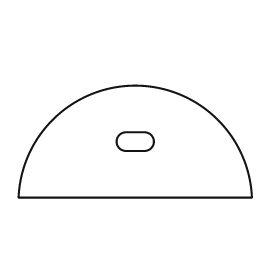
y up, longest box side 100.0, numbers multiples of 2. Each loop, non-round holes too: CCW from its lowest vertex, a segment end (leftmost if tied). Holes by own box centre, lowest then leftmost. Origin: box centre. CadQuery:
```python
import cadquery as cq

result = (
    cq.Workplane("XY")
    .moveTo(-50.0, -24.0)
    .lineTo(50.0, -24.0)
    .threePointArc((0.0, 24.0), (-50.0, -24.0))
    .close()
    .moveTo(-4.0, -4.0)
    .lineTo(4.0, -4.0)
    .threePointArc((8.0, 0.0), (4.0, 4.0))
    .lineTo(-4.0, 4.0)
    .threePointArc((-8.0, 0.0), (-4.0, -4.0))
    .close()
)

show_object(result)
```